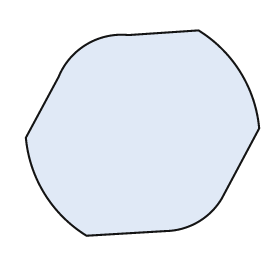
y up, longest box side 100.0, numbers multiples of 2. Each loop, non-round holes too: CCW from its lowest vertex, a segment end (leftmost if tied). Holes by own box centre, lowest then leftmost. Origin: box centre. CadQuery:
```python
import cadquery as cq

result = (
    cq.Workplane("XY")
    .moveTo(-24.0, -44.0)
    .lineTo(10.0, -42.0)
    .threePointArc((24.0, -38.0), (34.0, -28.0))
    .lineTo(50.0, 2.0)
    .threePointArc((42.0, 26.0), (24.0, 44.0))
    .lineTo(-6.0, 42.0)
    .threePointArc((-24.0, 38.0), (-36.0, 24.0))
    .lineTo(-50.0, -2.0)
    .threePointArc((-42.0, -26.0), (-24.0, -44.0))
    .close()
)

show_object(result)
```